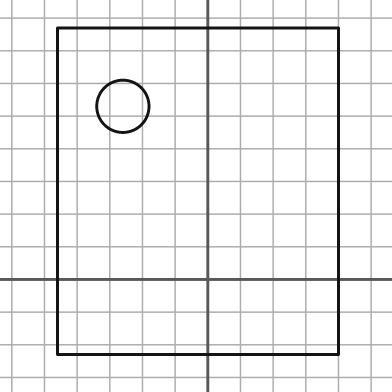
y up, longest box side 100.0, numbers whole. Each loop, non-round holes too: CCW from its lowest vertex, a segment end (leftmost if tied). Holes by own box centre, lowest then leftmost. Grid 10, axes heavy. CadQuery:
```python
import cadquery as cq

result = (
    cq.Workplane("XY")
    .moveTo(-46.0, -23.0)
    .lineTo(40.0, -23.0)
    .lineTo(40.0, 77.0)
    .lineTo(-46.0, 77.0)
    .close()
    .moveTo(-26.0, 53.0)
    .circle(8.0)
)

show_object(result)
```